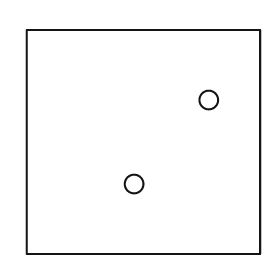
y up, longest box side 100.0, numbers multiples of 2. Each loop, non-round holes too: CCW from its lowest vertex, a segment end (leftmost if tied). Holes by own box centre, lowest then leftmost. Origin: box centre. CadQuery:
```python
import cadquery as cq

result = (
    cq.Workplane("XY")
    .moveTo(-50.0, -48.0)
    .lineTo(50.0, -48.0)
    .lineTo(50.0, 48.0)
    .lineTo(-50.0, 48.0)
    .close()
    .moveTo(-4.0, -18.0)
    .circle(4.0)
    .moveTo(28.0, 18.0)
    .circle(4.0)
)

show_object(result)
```